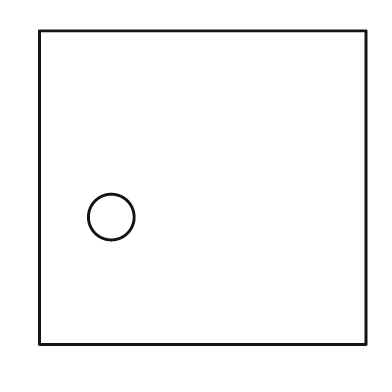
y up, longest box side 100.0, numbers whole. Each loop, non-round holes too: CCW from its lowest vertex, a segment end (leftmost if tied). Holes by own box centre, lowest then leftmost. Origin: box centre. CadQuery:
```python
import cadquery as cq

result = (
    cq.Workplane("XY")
    .moveTo(-50.0, -48.0)
    .lineTo(50.0, -48.0)
    .lineTo(50.0, 48.0)
    .lineTo(-50.0, 48.0)
    .close()
    .moveTo(-28.0, -9.0)
    .circle(7.0)
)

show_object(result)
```